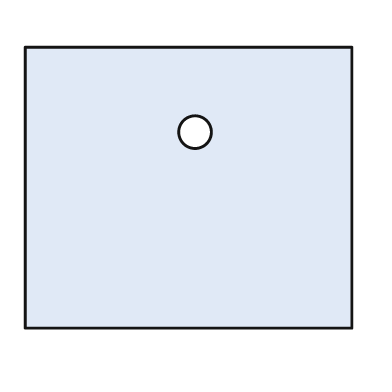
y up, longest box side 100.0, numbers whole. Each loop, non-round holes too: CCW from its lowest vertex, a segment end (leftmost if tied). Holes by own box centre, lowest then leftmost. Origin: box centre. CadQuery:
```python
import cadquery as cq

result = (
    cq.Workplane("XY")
    .moveTo(-50.0, -43.0)
    .lineTo(50.0, -43.0)
    .lineTo(50.0, 43.0)
    .lineTo(-50.0, 43.0)
    .close()
    .moveTo(2.0, 17.0)
    .circle(5.0)
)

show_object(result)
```